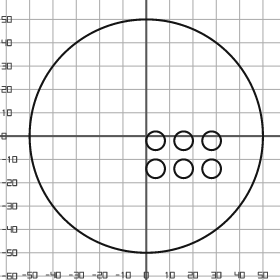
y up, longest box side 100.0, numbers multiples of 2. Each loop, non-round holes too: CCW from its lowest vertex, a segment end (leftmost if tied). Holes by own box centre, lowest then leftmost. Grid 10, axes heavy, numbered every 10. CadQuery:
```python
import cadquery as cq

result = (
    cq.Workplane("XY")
    .moveTo(0.0, 0.0)
    .circle(50.0)
    .moveTo(4.0, -14.0)
    .circle(4.0)
    .moveTo(16.0, -14.0)
    .circle(4.0)
    .moveTo(28.0, -14.0)
    .circle(4.0)
    .moveTo(4.0, -2.0)
    .circle(4.0)
    .moveTo(16.0, -2.0)
    .circle(4.0)
    .moveTo(28.0, -2.0)
    .circle(4.0)
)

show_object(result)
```